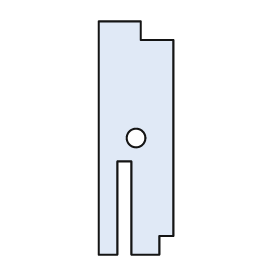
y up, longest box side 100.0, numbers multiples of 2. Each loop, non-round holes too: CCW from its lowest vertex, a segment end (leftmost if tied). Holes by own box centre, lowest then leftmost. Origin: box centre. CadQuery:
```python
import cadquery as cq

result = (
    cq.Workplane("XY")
    .moveTo(-16.0, -50.0)
    .lineTo(-8.0, -50.0)
    .lineTo(-8.0, -10.0)
    .lineTo(-2.0, -10.0)
    .lineTo(-2.0, -50.0)
    .lineTo(10.0, -50.0)
    .lineTo(10.0, -42.0)
    .lineTo(16.0, -42.0)
    .lineTo(16.0, 42.0)
    .lineTo(2.0, 42.0)
    .lineTo(2.0, 50.0)
    .lineTo(-16.0, 50.0)
    .close()
    .moveTo(0.0, 0.0)
    .circle(4.0)
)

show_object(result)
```